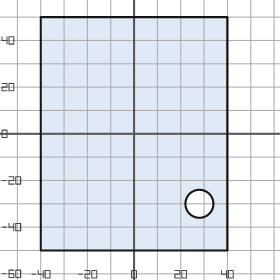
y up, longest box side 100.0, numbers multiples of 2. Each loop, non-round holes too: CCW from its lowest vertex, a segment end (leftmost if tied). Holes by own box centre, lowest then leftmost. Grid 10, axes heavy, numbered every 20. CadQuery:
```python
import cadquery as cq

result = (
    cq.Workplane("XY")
    .moveTo(-40.0, -50.0)
    .lineTo(40.0, -50.0)
    .lineTo(40.0, 50.0)
    .lineTo(-40.0, 50.0)
    .close()
    .moveTo(28.0, -30.0)
    .circle(6.0)
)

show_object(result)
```